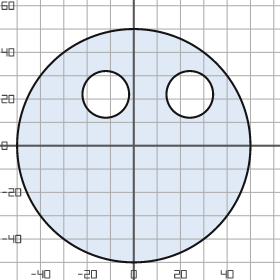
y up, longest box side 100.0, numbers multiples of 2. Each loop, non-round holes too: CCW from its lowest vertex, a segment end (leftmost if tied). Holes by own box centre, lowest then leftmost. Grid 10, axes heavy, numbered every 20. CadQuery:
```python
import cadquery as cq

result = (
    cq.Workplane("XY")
    .moveTo(0.0, 0.0)
    .circle(50.0)
    .moveTo(-12.0, 22.0)
    .circle(10.0)
    .moveTo(24.0, 22.0)
    .circle(10.0)
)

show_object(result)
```